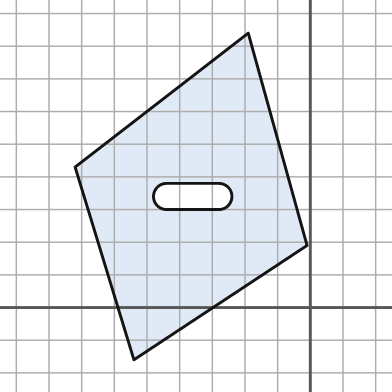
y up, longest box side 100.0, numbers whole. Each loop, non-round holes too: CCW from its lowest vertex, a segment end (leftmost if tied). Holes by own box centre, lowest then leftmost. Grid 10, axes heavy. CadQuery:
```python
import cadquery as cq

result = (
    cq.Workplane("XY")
    .moveTo(-54.0, -16.0)
    .lineTo(-1.0, 19.0)
    .lineTo(-19.0, 84.0)
    .lineTo(-72.0, 43.0)
    .close()
    .moveTo(-44.0, 30.0)
    .lineTo(-28.0, 30.0)
    .threePointArc((-24.0, 34.0), (-28.0, 38.0))
    .lineTo(-44.0, 38.0)
    .threePointArc((-48.0, 34.0), (-44.0, 30.0))
    .close()
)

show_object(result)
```